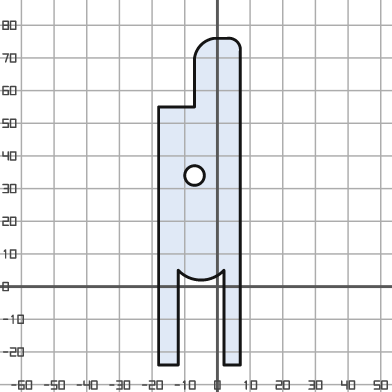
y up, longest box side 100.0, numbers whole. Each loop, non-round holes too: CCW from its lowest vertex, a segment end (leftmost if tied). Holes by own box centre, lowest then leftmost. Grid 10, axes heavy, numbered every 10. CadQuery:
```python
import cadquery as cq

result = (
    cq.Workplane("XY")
    .moveTo(-18.0, -24.0)
    .lineTo(-12.0, -24.0)
    .lineTo(-12.0, 5.0)
    .threePointArc((-5.0, 2.0), (2.0, 5.0))
    .lineTo(2.0, -24.0)
    .lineTo(7.0, -24.0)
    .lineTo(7.0, 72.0)
    .threePointArc((6.0, 75.0), (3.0, 76.0))
    .lineTo(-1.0, 76.0)
    .threePointArc((-5.0, 74.0), (-7.0, 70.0))
    .lineTo(-7.0, 55.0)
    .lineTo(-18.0, 55.0)
    .close()
    .moveTo(-7.0, 34.0)
    .circle(3.0)
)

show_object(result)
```